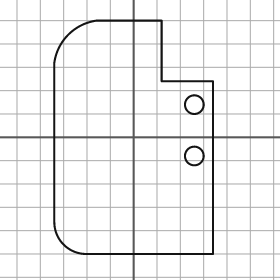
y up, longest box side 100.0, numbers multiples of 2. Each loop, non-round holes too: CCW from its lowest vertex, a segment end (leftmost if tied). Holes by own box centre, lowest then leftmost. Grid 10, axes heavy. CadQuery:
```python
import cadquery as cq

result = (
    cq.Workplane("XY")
    .moveTo(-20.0, -50.0)
    .lineTo(34.0, -50.0)
    .lineTo(34.0, 24.0)
    .lineTo(12.0, 24.0)
    .lineTo(12.0, 50.0)
    .lineTo(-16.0, 50.0)
    .threePointArc((-28.0, 44.0), (-34.0, 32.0))
    .lineTo(-34.0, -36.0)
    .threePointArc((-30.0, -46.0), (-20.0, -50.0))
    .close()
    .moveTo(26.0, -8.0)
    .circle(4.0)
    .moveTo(26.0, 14.0)
    .circle(4.0)
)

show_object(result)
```